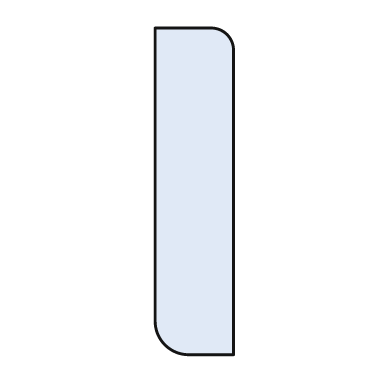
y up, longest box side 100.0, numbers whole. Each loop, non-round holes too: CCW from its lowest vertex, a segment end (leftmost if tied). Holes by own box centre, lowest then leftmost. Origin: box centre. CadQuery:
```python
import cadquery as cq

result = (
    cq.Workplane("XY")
    .moveTo(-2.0, -50.0)
    .lineTo(12.0, -50.0)
    .lineTo(12.0, 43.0)
    .threePointArc((10.0, 48.0), (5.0, 50.0))
    .lineTo(-12.0, 50.0)
    .lineTo(-12.0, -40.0)
    .threePointArc((-9.0, -47.0), (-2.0, -50.0))
    .close()
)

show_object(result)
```